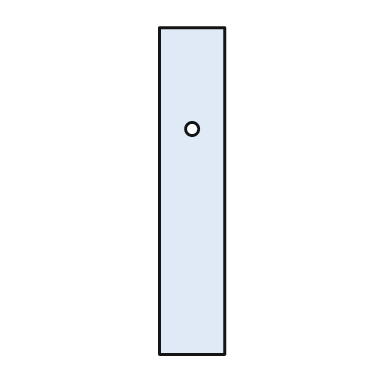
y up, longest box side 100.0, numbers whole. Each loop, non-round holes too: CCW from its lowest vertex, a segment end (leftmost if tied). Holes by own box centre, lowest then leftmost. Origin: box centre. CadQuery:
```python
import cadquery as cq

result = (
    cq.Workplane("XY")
    .moveTo(-10.0, -50.0)
    .lineTo(10.0, -50.0)
    .lineTo(10.0, 50.0)
    .lineTo(-10.0, 50.0)
    .close()
    .moveTo(0.0, 19.0)
    .circle(2.0)
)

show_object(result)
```